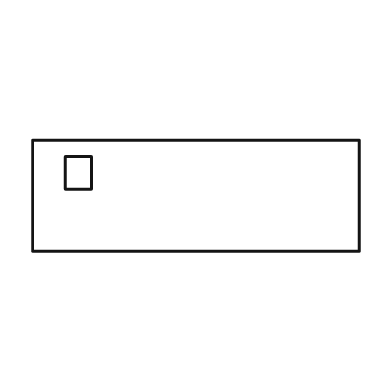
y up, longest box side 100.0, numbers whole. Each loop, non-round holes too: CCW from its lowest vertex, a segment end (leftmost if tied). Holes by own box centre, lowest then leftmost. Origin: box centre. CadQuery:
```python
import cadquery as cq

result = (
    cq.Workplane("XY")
    .moveTo(-50.0, -17.0)
    .lineTo(50.0, -17.0)
    .lineTo(50.0, 17.0)
    .lineTo(-50.0, 17.0)
    .close()
    .moveTo(-40.0, 2.0)
    .lineTo(-32.0, 2.0)
    .lineTo(-32.0, 12.0)
    .lineTo(-40.0, 12.0)
    .close()
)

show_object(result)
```